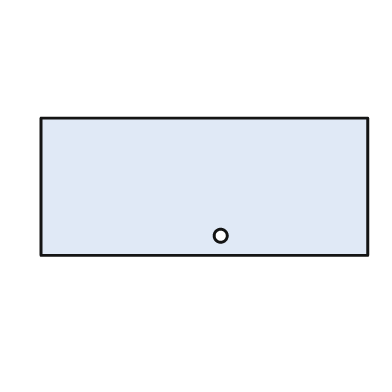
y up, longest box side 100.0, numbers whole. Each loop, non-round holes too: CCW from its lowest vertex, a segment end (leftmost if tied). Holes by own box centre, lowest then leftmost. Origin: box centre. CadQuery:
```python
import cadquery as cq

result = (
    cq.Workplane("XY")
    .moveTo(-50.0, -21.0)
    .lineTo(50.0, -21.0)
    .lineTo(50.0, 21.0)
    .lineTo(-50.0, 21.0)
    .close()
    .moveTo(5.0, -15.0)
    .circle(2.0)
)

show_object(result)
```